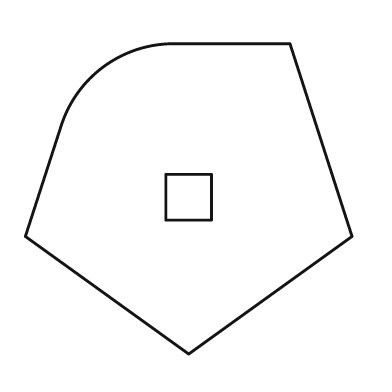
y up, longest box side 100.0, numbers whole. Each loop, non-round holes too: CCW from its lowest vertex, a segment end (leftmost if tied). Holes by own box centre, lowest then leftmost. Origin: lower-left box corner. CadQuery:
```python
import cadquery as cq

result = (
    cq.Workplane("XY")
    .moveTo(50.0, 0.0)
    .lineTo(100.0, 36.0)
    .lineTo(81.0, 95.0)
    .lineTo(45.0, 95.0)
    .threePointArc((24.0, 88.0), (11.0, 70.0))
    .lineTo(0.0, 36.0)
    .close()
    .moveTo(43.0, 41.0)
    .lineTo(57.0, 41.0)
    .lineTo(57.0, 55.0)
    .lineTo(43.0, 55.0)
    .close()
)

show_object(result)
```